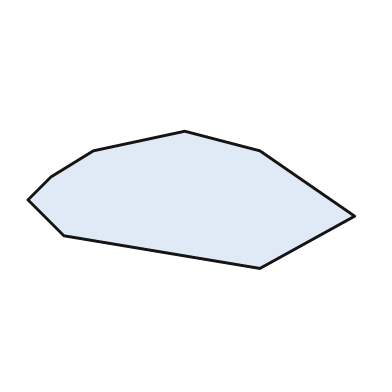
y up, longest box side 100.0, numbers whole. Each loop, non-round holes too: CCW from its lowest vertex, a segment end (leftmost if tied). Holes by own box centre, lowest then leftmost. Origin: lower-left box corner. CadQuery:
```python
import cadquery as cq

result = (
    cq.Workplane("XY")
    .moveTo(71.0, 0.0)
    .lineTo(100.0, 16.0)
    .lineTo(71.0, 36.0)
    .lineTo(48.0, 42.0)
    .lineTo(20.0, 36.0)
    .lineTo(7.0, 28.0)
    .lineTo(0.0, 21.0)
    .lineTo(11.0, 10.0)
    .close()
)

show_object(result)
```